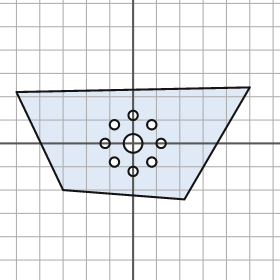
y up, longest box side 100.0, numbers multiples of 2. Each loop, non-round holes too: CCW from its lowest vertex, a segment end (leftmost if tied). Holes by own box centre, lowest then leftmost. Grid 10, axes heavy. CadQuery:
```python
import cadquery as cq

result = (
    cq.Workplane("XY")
    .moveTo(22.0, -24.0)
    .lineTo(50.0, 24.0)
    .lineTo(-50.0, 22.0)
    .lineTo(-30.0, -20.0)
    .close()
    .moveTo(0.0, -12.0)
    .circle(2.0)
    .moveTo(-8.0, -8.0)
    .circle(2.0)
    .moveTo(8.0, -8.0)
    .circle(2.0)
    .moveTo(-12.0, 0.0)
    .circle(2.0)
    .moveTo(0.0, 0.0)
    .circle(4.0)
    .moveTo(12.0, 0.0)
    .circle(2.0)
    .moveTo(-8.0, 8.0)
    .circle(2.0)
    .moveTo(8.0, 8.0)
    .circle(2.0)
    .moveTo(0.0, 12.0)
    .circle(2.0)
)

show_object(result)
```